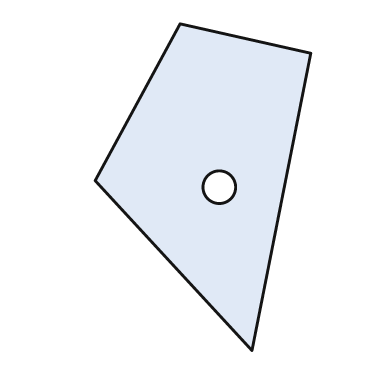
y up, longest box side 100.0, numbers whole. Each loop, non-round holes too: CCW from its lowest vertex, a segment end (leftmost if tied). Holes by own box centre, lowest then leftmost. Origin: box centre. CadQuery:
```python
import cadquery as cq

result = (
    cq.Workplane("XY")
    .moveTo(15.0, -50.0)
    .lineTo(33.0, 41.0)
    .lineTo(-7.0, 50.0)
    .lineTo(-33.0, 2.0)
    .close()
    .moveTo(5.0, 0.0)
    .circle(5.0)
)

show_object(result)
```